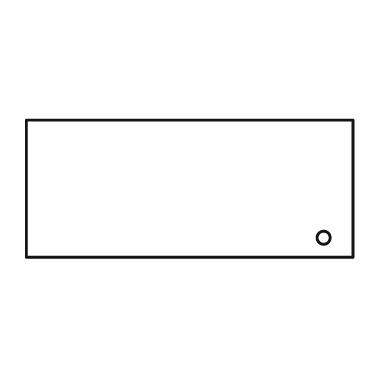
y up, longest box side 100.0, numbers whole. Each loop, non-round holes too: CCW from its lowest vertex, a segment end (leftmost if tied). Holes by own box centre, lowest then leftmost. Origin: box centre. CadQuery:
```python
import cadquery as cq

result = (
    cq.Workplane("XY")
    .moveTo(-50.0, -21.0)
    .lineTo(50.0, -21.0)
    .lineTo(50.0, 21.0)
    .lineTo(-50.0, 21.0)
    .close()
    .moveTo(41.0, -15.0)
    .circle(2.0)
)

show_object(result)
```